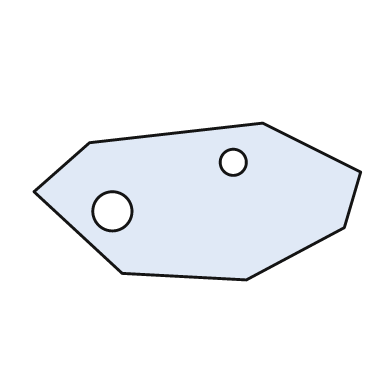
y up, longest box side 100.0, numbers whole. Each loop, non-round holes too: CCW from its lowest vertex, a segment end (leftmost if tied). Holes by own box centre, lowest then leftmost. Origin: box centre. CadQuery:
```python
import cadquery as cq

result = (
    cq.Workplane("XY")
    .moveTo(15.0, -24.0)
    .lineTo(45.0, -8.0)
    .lineTo(50.0, 9.0)
    .lineTo(20.0, 24.0)
    .lineTo(-33.0, 18.0)
    .lineTo(-50.0, 3.0)
    .lineTo(-23.0, -22.0)
    .close()
    .moveTo(-26.0, -3.0)
    .circle(6.0)
    .moveTo(11.0, 12.0)
    .circle(4.0)
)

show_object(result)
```